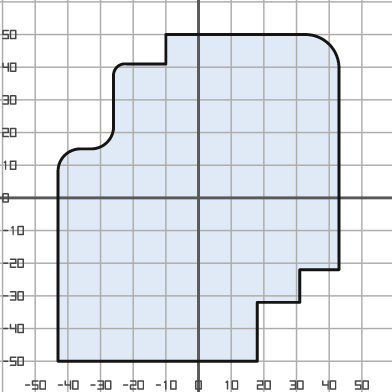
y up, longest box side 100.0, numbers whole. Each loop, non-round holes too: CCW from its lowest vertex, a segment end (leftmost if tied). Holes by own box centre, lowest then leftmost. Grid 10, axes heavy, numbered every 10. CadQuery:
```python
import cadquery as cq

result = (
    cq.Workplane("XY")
    .moveTo(-43.0, -50.0)
    .lineTo(18.0, -50.0)
    .lineTo(18.0, -32.0)
    .lineTo(31.0, -32.0)
    .lineTo(31.0, -22.0)
    .lineTo(43.0, -22.0)
    .lineTo(43.0, 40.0)
    .threePointArc((40.0, 47.0), (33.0, 50.0))
    .lineTo(-10.0, 50.0)
    .lineTo(-10.0, 41.0)
    .lineTo(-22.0, 41.0)
    .threePointArc((-25.0, 40.0), (-26.0, 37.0))
    .lineTo(-26.0, 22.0)
    .threePointArc((-28.0, 17.0), (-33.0, 15.0))
    .lineTo(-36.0, 15.0)
    .threePointArc((-41.0, 13.0), (-43.0, 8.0))
    .close()
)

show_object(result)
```